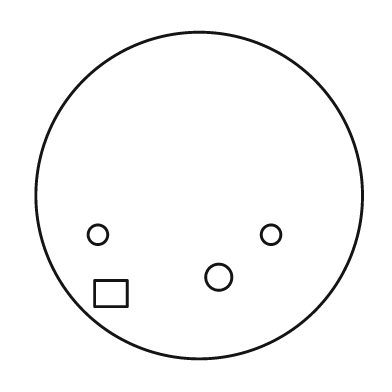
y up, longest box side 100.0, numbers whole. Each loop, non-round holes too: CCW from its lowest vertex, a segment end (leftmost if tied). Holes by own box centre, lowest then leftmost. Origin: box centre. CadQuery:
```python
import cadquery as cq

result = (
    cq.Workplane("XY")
    .moveTo(0.0, 0.0)
    .circle(50.0)
    .moveTo(-32.0, -34.0)
    .lineTo(-22.0, -34.0)
    .lineTo(-22.0, -26.0)
    .lineTo(-32.0, -26.0)
    .close()
    .moveTo(6.0, -25.0)
    .circle(4.0)
    .moveTo(-31.0, -12.0)
    .circle(3.0)
    .moveTo(22.0, -12.0)
    .circle(3.0)
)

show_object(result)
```